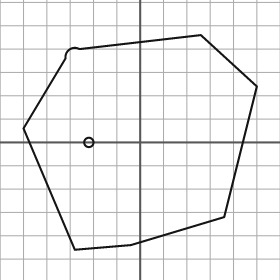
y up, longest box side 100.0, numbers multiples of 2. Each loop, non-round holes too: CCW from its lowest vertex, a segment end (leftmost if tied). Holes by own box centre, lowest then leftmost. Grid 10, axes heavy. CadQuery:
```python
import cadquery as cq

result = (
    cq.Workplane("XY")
    .moveTo(-28.0, -46.0)
    .lineTo(-4.0, -44.0)
    .lineTo(36.0, -32.0)
    .lineTo(50.0, 24.0)
    .lineTo(26.0, 46.0)
    .lineTo(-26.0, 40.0)
    .threePointArc((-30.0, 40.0), (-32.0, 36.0))
    .lineTo(-50.0, 6.0)
    .close()
    .moveTo(-22.0, 0.0)
    .circle(2.0)
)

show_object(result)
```